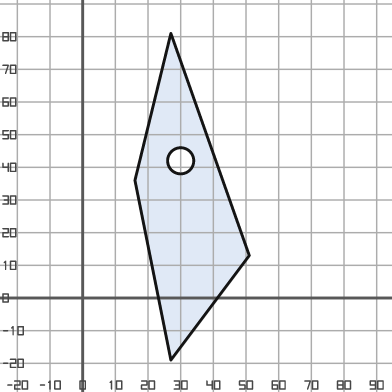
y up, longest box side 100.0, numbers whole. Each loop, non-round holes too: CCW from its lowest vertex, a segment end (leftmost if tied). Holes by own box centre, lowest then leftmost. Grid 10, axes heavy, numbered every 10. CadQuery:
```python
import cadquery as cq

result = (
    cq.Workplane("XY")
    .moveTo(27.0, -19.0)
    .lineTo(51.0, 13.0)
    .lineTo(27.0, 81.0)
    .lineTo(16.0, 36.0)
    .close()
    .moveTo(30.0, 42.0)
    .circle(4.0)
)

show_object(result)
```